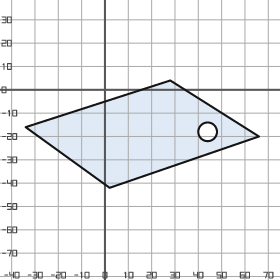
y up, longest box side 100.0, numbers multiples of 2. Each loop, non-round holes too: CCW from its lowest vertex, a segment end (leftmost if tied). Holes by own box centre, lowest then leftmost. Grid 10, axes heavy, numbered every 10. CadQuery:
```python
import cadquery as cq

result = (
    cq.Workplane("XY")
    .moveTo(2.0, -42.0)
    .lineTo(66.0, -20.0)
    .lineTo(28.0, 4.0)
    .lineTo(-34.0, -16.0)
    .close()
    .moveTo(44.0, -18.0)
    .circle(4.0)
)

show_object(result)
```